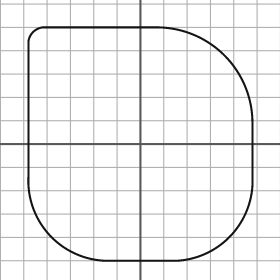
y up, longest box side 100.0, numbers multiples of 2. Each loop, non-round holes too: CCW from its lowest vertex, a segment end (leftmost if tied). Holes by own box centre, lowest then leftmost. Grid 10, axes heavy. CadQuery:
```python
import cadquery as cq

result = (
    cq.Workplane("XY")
    .moveTo(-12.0, -50.0)
    .lineTo(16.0, -50.0)
    .threePointArc((38.0, -40.0), (48.0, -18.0))
    .lineTo(48.0, 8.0)
    .threePointArc((36.0, 38.0), (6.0, 50.0))
    .lineTo(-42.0, 50.0)
    .threePointArc((-46.0, 48.0), (-48.0, 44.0))
    .lineTo(-48.0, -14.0)
    .threePointArc((-38.0, -40.0), (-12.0, -50.0))
    .close()
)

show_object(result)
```